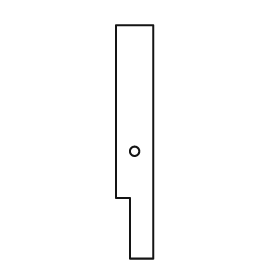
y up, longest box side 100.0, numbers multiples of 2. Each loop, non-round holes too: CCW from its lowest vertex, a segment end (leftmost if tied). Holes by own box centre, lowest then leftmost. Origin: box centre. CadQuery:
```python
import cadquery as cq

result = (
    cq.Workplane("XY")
    .moveTo(-2.0, -50.0)
    .lineTo(8.0, -50.0)
    .lineTo(8.0, 50.0)
    .lineTo(-8.0, 50.0)
    .lineTo(-8.0, -24.0)
    .lineTo(-2.0, -24.0)
    .close()
    .moveTo(0.0, -4.0)
    .circle(2.0)
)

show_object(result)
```